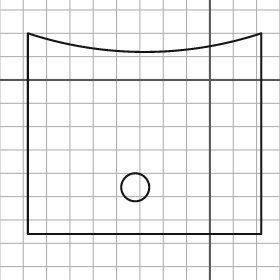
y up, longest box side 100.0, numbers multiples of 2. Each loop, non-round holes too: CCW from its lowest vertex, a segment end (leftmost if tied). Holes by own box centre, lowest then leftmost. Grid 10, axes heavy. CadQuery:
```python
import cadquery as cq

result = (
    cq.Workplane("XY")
    .moveTo(-78.0, -66.0)
    .lineTo(22.0, -66.0)
    .lineTo(22.0, 20.0)
    .threePointArc((-28.0, 12.0), (-78.0, 20.0))
    .close()
    .moveTo(-32.0, -46.0)
    .circle(6.0)
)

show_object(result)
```